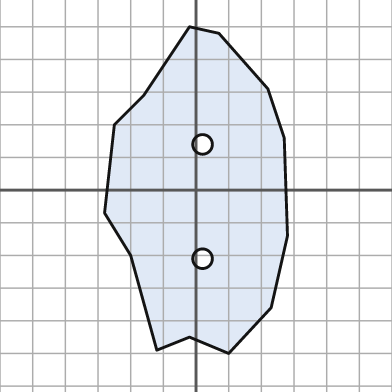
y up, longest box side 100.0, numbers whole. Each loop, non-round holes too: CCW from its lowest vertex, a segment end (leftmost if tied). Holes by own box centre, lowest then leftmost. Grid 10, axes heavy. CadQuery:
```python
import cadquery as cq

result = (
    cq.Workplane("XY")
    .moveTo(10.0, -50.0)
    .lineTo(23.0, -36.0)
    .lineTo(28.0, -14.0)
    .lineTo(27.0, 16.0)
    .lineTo(22.0, 31.0)
    .lineTo(7.0, 48.0)
    .lineTo(-2.0, 50.0)
    .lineTo(-16.0, 29.0)
    .lineTo(-25.0, 20.0)
    .lineTo(-28.0, -7.0)
    .lineTo(-20.0, -20.0)
    .lineTo(-12.0, -49.0)
    .lineTo(-2.0, -45.0)
    .close()
    .moveTo(2.0, -21.0)
    .circle(3.0)
    .moveTo(2.0, 14.0)
    .circle(3.0)
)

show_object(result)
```